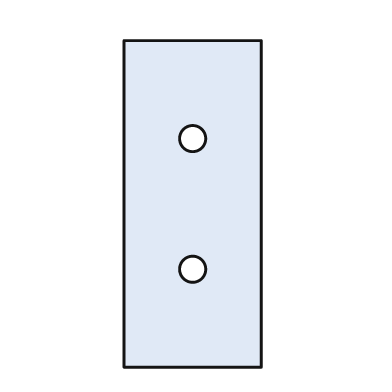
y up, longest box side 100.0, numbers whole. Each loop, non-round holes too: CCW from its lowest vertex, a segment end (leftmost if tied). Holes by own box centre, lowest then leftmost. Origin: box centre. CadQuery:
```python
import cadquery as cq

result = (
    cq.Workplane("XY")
    .moveTo(-21.0, -50.0)
    .lineTo(21.0, -50.0)
    .lineTo(21.0, 50.0)
    .lineTo(-21.0, 50.0)
    .close()
    .moveTo(0.0, -20.0)
    .circle(4.0)
    .moveTo(0.0, 20.0)
    .circle(4.0)
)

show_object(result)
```